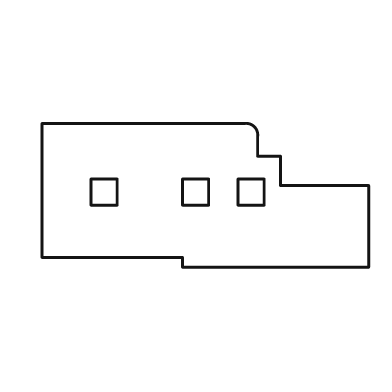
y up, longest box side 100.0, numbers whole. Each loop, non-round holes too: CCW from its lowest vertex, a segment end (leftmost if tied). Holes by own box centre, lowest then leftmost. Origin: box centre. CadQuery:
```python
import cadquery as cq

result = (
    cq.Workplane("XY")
    .moveTo(-7.0, -22.0)
    .lineTo(50.0, -22.0)
    .lineTo(50.0, 3.0)
    .lineTo(23.0, 3.0)
    .lineTo(23.0, 12.0)
    .lineTo(16.0, 12.0)
    .lineTo(16.0, 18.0)
    .threePointArc((15.0, 21.0), (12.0, 22.0))
    .lineTo(-50.0, 22.0)
    .lineTo(-50.0, -19.0)
    .lineTo(-7.0, -19.0)
    .close()
    .moveTo(-35.0, -3.0)
    .lineTo(-27.0, -3.0)
    .lineTo(-27.0, 5.0)
    .lineTo(-35.0, 5.0)
    .close()
    .moveTo(-7.0, -3.0)
    .lineTo(1.0, -3.0)
    .lineTo(1.0, 5.0)
    .lineTo(-7.0, 5.0)
    .close()
    .moveTo(10.0, -3.0)
    .lineTo(18.0, -3.0)
    .lineTo(18.0, 5.0)
    .lineTo(10.0, 5.0)
    .close()
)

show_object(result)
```